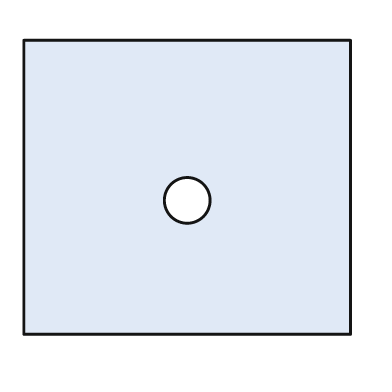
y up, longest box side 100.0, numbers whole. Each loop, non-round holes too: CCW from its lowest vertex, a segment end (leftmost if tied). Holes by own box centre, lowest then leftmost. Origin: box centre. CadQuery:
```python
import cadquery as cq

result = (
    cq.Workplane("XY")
    .moveTo(-50.0, -45.0)
    .lineTo(50.0, -45.0)
    .lineTo(50.0, 45.0)
    .lineTo(-50.0, 45.0)
    .close()
    .moveTo(0.0, -4.0)
    .circle(7.0)
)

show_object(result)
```